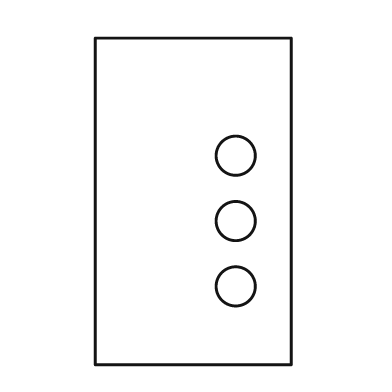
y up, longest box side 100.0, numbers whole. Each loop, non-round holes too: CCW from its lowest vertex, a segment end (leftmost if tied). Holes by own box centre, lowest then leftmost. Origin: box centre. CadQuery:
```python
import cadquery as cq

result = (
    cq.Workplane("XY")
    .moveTo(-30.0, -50.0)
    .lineTo(30.0, -50.0)
    .lineTo(30.0, 50.0)
    .lineTo(-30.0, 50.0)
    .close()
    .moveTo(13.0, -26.0)
    .circle(6.0)
    .moveTo(13.0, -6.0)
    .circle(6.0)
    .moveTo(13.0, 14.0)
    .circle(6.0)
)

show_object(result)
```